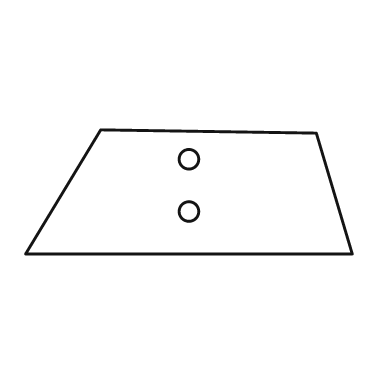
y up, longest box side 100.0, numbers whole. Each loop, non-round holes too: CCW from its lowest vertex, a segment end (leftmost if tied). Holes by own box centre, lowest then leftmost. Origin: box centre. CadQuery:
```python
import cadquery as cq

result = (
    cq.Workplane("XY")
    .moveTo(-50.0, -19.0)
    .lineTo(50.0, -19.0)
    .lineTo(39.0, 18.0)
    .lineTo(-27.0, 19.0)
    .close()
    .moveTo(0.0, -6.0)
    .circle(3.0)
    .moveTo(0.0, 10.0)
    .circle(3.0)
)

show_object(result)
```